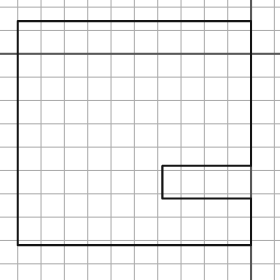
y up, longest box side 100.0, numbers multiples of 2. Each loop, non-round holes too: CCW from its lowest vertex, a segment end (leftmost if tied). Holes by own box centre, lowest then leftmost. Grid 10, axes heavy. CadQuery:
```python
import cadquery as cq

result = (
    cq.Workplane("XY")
    .moveTo(-100.0, -82.0)
    .lineTo(0.0, -82.0)
    .lineTo(0.0, -62.0)
    .lineTo(-38.0, -62.0)
    .lineTo(-38.0, -48.0)
    .lineTo(0.0, -48.0)
    .lineTo(0.0, 14.0)
    .lineTo(-100.0, 14.0)
    .close()
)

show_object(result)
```